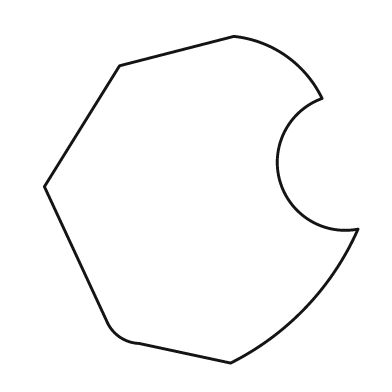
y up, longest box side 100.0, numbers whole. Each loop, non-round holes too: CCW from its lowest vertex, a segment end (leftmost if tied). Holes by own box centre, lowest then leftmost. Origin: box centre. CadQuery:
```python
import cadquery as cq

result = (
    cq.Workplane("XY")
    .moveTo(9.0, -50.0)
    .threePointArc((32.0, -33.0), (48.0, -9.0))
    .threePointArc((24.0, 6.0), (37.0, 31.0))
    .threePointArc((26.0, 44.0), (10.0, 50.0))
    .lineTo(-25.0, 41.0)
    .lineTo(-48.0, 4.0)
    .lineTo(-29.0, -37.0)
    .threePointArc((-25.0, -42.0), (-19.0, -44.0))
    .close()
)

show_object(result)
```